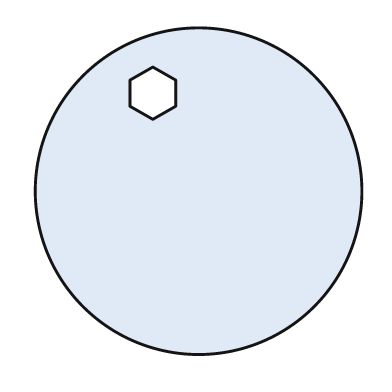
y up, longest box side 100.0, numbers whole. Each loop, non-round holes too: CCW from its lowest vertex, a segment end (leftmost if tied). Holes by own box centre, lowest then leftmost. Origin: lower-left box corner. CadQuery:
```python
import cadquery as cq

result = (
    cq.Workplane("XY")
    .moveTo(50.0, 50.0)
    .circle(50.0)
    .moveTo(36.0, 72.0)
    .lineTo(43.0, 76.0)
    .lineTo(43.0, 84.0)
    .lineTo(36.0, 88.0)
    .lineTo(29.0, 84.0)
    .lineTo(29.0, 76.0)
    .close()
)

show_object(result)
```